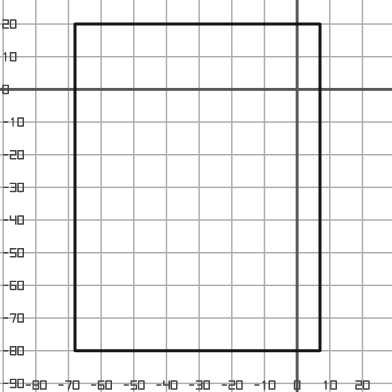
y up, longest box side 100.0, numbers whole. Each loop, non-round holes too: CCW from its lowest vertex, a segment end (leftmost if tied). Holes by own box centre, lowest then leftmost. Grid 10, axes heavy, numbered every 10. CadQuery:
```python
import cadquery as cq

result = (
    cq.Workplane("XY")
    .moveTo(-68.0, -80.0)
    .lineTo(7.0, -80.0)
    .lineTo(7.0, 20.0)
    .lineTo(-68.0, 20.0)
    .close()
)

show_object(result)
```